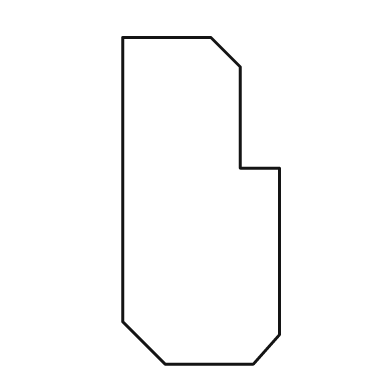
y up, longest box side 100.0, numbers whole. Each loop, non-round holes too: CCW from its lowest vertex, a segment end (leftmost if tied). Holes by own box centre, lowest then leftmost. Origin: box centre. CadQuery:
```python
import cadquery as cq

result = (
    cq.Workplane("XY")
    .moveTo(-11.0, -50.0)
    .lineTo(16.0, -50.0)
    .lineTo(24.0, -41.0)
    .lineTo(24.0, 10.0)
    .lineTo(12.0, 10.0)
    .lineTo(12.0, 41.0)
    .lineTo(3.0, 50.0)
    .lineTo(-24.0, 50.0)
    .lineTo(-24.0, -37.0)
    .close()
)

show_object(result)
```